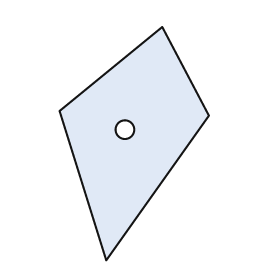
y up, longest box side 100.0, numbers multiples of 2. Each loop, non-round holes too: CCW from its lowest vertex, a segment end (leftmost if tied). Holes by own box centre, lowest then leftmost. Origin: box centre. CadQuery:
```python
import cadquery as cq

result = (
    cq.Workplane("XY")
    .moveTo(-12.0, -50.0)
    .lineTo(32.0, 12.0)
    .lineTo(12.0, 50.0)
    .lineTo(-32.0, 14.0)
    .close()
    .moveTo(-4.0, 6.0)
    .circle(4.0)
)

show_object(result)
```